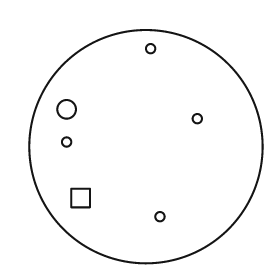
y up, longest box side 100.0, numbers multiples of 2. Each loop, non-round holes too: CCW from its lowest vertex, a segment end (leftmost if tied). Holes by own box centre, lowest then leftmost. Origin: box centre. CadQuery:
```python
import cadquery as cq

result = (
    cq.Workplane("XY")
    .moveTo(0.0, 0.0)
    .circle(50.0)
    .moveTo(6.0, -30.0)
    .circle(2.0)
    .moveTo(-32.0, -26.0)
    .lineTo(-24.0, -26.0)
    .lineTo(-24.0, -18.0)
    .lineTo(-32.0, -18.0)
    .close()
    .moveTo(-34.0, 2.0)
    .circle(2.0)
    .moveTo(22.0, 12.0)
    .circle(2.0)
    .moveTo(-34.0, 16.0)
    .circle(4.0)
    .moveTo(2.0, 42.0)
    .circle(2.0)
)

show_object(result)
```